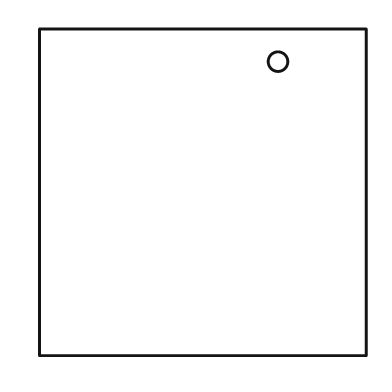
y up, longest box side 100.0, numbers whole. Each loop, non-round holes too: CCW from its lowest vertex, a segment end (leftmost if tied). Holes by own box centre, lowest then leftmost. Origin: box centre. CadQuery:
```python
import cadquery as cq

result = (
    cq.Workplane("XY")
    .moveTo(-50.0, -50.0)
    .lineTo(50.0, -50.0)
    .lineTo(50.0, 50.0)
    .lineTo(-50.0, 50.0)
    .close()
    .moveTo(23.0, 40.0)
    .circle(3.0)
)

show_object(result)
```